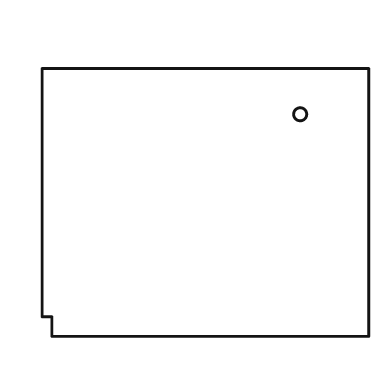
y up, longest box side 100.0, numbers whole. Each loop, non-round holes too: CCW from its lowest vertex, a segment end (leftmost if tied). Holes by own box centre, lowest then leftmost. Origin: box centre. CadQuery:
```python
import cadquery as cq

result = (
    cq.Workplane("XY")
    .moveTo(-47.0, -41.0)
    .lineTo(50.0, -41.0)
    .lineTo(50.0, 41.0)
    .lineTo(-50.0, 41.0)
    .lineTo(-50.0, -35.0)
    .lineTo(-47.0, -35.0)
    .close()
    .moveTo(29.0, 27.0)
    .circle(2.0)
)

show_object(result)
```